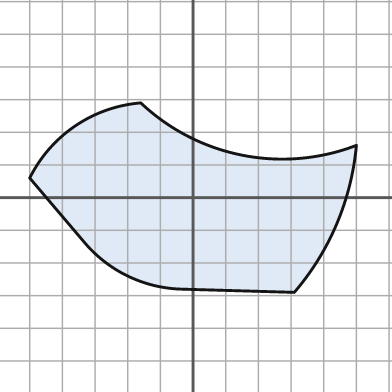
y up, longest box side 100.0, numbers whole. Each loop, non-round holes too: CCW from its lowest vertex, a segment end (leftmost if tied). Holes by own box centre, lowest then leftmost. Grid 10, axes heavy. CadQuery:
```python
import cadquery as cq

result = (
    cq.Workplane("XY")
    .moveTo(31.0, -29.0)
    .threePointArc((44.0, -8.0), (50.0, 16.0))
    .threePointArc((15.0, 13.0), (-16.0, 29.0))
    .threePointArc((-36.0, 22.0), (-50.0, 6.0))
    .lineTo(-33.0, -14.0)
    .threePointArc((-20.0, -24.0), (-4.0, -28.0))
    .close()
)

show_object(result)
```